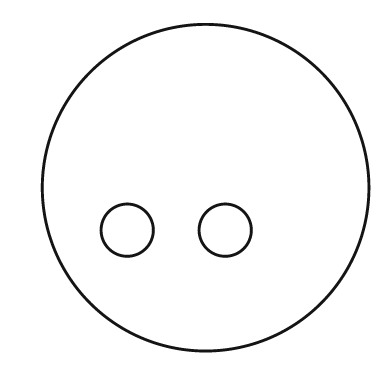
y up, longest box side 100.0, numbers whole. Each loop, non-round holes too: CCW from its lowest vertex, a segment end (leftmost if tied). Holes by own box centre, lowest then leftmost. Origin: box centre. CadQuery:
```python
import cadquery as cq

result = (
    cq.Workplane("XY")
    .moveTo(0.0, 0.0)
    .circle(50.0)
    .moveTo(-24.0, -13.0)
    .circle(8.0)
    .moveTo(6.0, -13.0)
    .circle(8.0)
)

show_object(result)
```